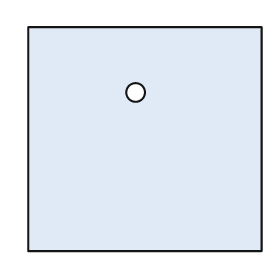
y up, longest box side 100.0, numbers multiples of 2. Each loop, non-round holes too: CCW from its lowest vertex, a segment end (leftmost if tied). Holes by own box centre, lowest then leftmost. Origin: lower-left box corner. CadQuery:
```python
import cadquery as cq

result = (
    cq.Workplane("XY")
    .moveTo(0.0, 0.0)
    .lineTo(100.0, 0.0)
    .lineTo(100.0, 96.0)
    .lineTo(0.0, 96.0)
    .close()
    .moveTo(46.0, 68.0)
    .circle(4.0)
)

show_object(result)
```